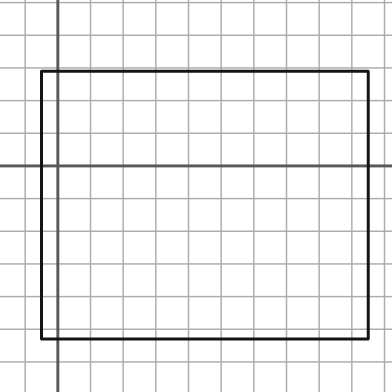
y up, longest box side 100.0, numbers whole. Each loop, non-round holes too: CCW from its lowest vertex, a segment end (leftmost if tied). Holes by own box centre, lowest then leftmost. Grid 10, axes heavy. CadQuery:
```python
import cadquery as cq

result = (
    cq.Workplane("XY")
    .moveTo(-5.0, -53.0)
    .lineTo(95.0, -53.0)
    .lineTo(95.0, 29.0)
    .lineTo(-5.0, 29.0)
    .close()
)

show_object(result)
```